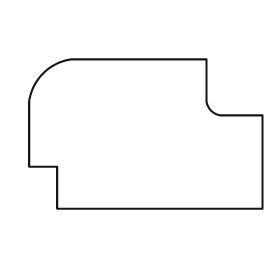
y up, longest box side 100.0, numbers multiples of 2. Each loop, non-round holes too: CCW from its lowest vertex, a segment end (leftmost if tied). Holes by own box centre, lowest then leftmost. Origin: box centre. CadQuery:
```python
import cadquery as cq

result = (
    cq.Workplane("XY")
    .moveTo(-38.0, -32.0)
    .lineTo(50.0, -32.0)
    .lineTo(50.0, 8.0)
    .lineTo(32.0, 8.0)
    .threePointArc((28.0, 10.0), (26.0, 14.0))
    .lineTo(26.0, 32.0)
    .lineTo(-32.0, 32.0)
    .threePointArc((-44.0, 26.0), (-50.0, 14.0))
    .lineTo(-50.0, -14.0)
    .lineTo(-38.0, -14.0)
    .close()
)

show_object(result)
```